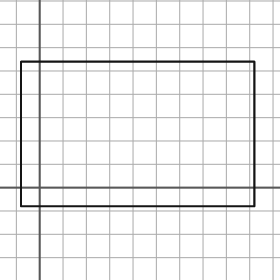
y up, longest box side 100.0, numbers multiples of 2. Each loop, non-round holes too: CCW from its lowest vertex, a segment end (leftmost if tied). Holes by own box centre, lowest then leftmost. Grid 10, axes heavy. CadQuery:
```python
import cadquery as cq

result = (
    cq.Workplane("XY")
    .moveTo(-8.0, -8.0)
    .lineTo(92.0, -8.0)
    .lineTo(92.0, 54.0)
    .lineTo(-8.0, 54.0)
    .close()
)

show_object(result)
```